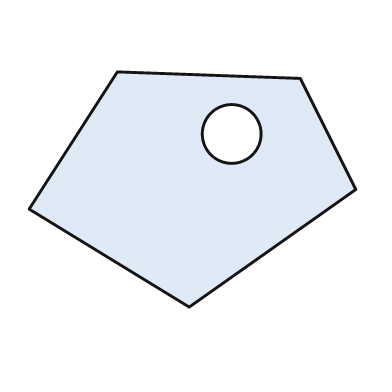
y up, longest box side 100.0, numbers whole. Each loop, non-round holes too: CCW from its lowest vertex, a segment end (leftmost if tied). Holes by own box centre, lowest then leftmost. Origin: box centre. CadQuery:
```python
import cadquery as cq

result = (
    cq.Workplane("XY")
    .moveTo(-1.0, -36.0)
    .lineTo(50.0, 0.0)
    .lineTo(33.0, 34.0)
    .lineTo(-23.0, 36.0)
    .lineTo(-50.0, -6.0)
    .close()
    .moveTo(12.0, 17.0)
    .circle(9.0)
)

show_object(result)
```